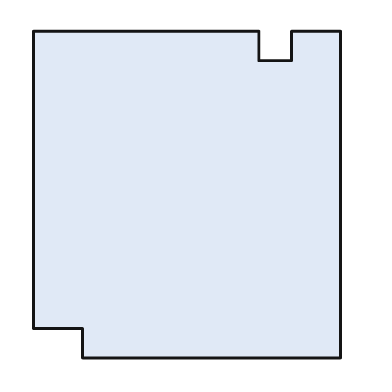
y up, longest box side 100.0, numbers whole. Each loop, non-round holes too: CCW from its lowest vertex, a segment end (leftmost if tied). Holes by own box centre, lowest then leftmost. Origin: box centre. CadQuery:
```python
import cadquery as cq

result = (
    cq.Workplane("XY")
    .moveTo(-32.0, -50.0)
    .lineTo(47.0, -50.0)
    .lineTo(47.0, 50.0)
    .lineTo(32.0, 50.0)
    .lineTo(32.0, 41.0)
    .lineTo(22.0, 41.0)
    .lineTo(22.0, 50.0)
    .lineTo(-47.0, 50.0)
    .lineTo(-47.0, -41.0)
    .lineTo(-32.0, -41.0)
    .close()
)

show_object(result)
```